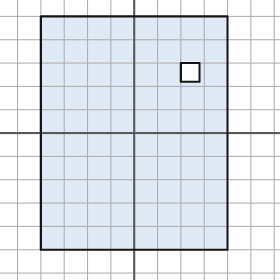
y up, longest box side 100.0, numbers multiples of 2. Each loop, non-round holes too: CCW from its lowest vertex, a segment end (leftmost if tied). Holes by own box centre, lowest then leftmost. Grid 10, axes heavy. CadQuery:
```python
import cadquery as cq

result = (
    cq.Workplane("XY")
    .moveTo(-40.0, -50.0)
    .lineTo(40.0, -50.0)
    .lineTo(40.0, 50.0)
    .lineTo(-40.0, 50.0)
    .close()
    .moveTo(20.0, 22.0)
    .lineTo(28.0, 22.0)
    .lineTo(28.0, 30.0)
    .lineTo(20.0, 30.0)
    .close()
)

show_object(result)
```